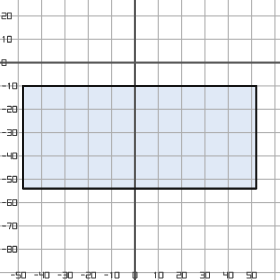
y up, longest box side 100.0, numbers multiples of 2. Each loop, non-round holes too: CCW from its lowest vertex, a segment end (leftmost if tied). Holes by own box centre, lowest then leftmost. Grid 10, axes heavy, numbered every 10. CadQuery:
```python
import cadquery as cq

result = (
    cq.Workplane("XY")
    .moveTo(-48.0, -54.0)
    .lineTo(52.0, -54.0)
    .lineTo(52.0, -10.0)
    .lineTo(-48.0, -10.0)
    .close()
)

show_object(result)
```